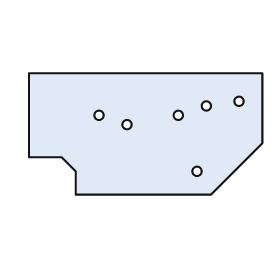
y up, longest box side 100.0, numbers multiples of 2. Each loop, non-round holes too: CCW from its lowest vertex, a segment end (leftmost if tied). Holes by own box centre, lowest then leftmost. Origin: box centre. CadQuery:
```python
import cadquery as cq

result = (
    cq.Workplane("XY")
    .moveTo(-30.0, -26.0)
    .lineTo(28.0, -26.0)
    .lineTo(50.0, -4.0)
    .lineTo(50.0, 26.0)
    .lineTo(-50.0, 26.0)
    .lineTo(-50.0, -10.0)
    .lineTo(-36.0, -10.0)
    .lineTo(-30.0, -16.0)
    .close()
    .moveTo(22.0, -16.0)
    .circle(2.0)
    .moveTo(-8.0, 4.0)
    .circle(2.0)
    .moveTo(-20.0, 8.0)
    .circle(2.0)
    .moveTo(14.0, 8.0)
    .circle(2.0)
    .moveTo(26.0, 12.0)
    .circle(2.0)
    .moveTo(40.0, 14.0)
    .circle(2.0)
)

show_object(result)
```